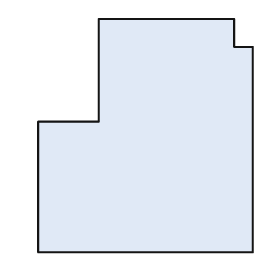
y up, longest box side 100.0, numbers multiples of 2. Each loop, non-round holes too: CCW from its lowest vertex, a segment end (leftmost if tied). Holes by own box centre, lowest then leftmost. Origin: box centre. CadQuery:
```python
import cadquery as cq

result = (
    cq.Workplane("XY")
    .moveTo(-46.0, -50.0)
    .lineTo(46.0, -50.0)
    .lineTo(46.0, 38.0)
    .lineTo(38.0, 38.0)
    .lineTo(38.0, 50.0)
    .lineTo(-20.0, 50.0)
    .lineTo(-20.0, 6.0)
    .lineTo(-46.0, 6.0)
    .close()
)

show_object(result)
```